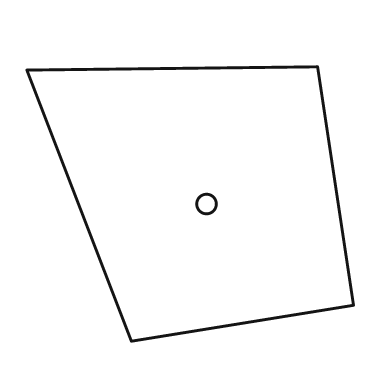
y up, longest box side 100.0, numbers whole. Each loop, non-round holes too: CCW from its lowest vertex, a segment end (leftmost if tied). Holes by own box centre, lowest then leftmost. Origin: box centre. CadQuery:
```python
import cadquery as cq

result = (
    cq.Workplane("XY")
    .moveTo(-18.0, -42.0)
    .lineTo(50.0, -31.0)
    .lineTo(39.0, 42.0)
    .lineTo(-50.0, 41.0)
    .close()
    .moveTo(5.0, 0.0)
    .circle(3.0)
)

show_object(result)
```